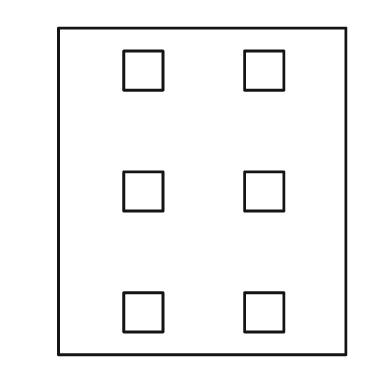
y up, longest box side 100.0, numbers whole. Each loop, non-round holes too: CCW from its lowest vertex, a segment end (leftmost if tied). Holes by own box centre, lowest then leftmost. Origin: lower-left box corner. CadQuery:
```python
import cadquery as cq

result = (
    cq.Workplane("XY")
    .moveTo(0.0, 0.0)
    .lineTo(88.0, 0.0)
    .lineTo(88.0, 100.0)
    .lineTo(0.0, 100.0)
    .close()
    .moveTo(20.0, 7.0)
    .lineTo(32.0, 7.0)
    .lineTo(32.0, 19.0)
    .lineTo(20.0, 19.0)
    .close()
    .moveTo(57.0, 7.0)
    .lineTo(69.0, 7.0)
    .lineTo(69.0, 19.0)
    .lineTo(57.0, 19.0)
    .close()
    .moveTo(20.0, 44.0)
    .lineTo(32.0, 44.0)
    .lineTo(32.0, 56.0)
    .lineTo(20.0, 56.0)
    .close()
    .moveTo(57.0, 44.0)
    .lineTo(69.0, 44.0)
    .lineTo(69.0, 56.0)
    .lineTo(57.0, 56.0)
    .close()
    .moveTo(20.0, 81.0)
    .lineTo(32.0, 81.0)
    .lineTo(32.0, 93.0)
    .lineTo(20.0, 93.0)
    .close()
    .moveTo(57.0, 81.0)
    .lineTo(69.0, 81.0)
    .lineTo(69.0, 93.0)
    .lineTo(57.0, 93.0)
    .close()
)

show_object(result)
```